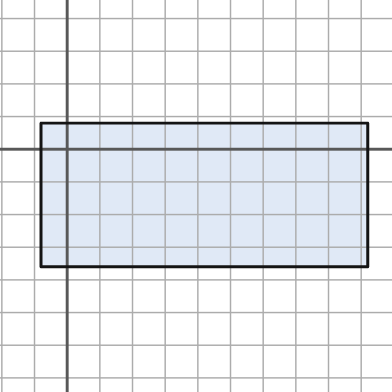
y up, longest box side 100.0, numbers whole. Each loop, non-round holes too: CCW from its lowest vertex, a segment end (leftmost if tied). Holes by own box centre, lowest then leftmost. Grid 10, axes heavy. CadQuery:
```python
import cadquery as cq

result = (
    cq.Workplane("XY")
    .moveTo(-8.0, -36.0)
    .lineTo(92.0, -36.0)
    .lineTo(92.0, 8.0)
    .lineTo(-8.0, 8.0)
    .close()
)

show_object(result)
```